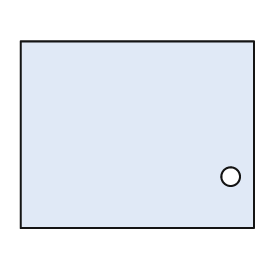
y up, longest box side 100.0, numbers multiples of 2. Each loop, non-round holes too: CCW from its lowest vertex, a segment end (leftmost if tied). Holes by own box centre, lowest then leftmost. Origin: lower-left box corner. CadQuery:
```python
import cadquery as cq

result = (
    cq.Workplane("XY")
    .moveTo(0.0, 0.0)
    .lineTo(100.0, 0.0)
    .lineTo(100.0, 80.0)
    .lineTo(0.0, 80.0)
    .close()
    .moveTo(90.0, 22.0)
    .circle(4.0)
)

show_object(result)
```